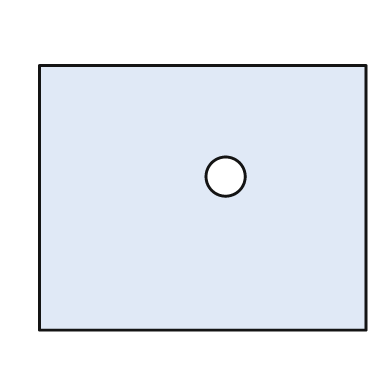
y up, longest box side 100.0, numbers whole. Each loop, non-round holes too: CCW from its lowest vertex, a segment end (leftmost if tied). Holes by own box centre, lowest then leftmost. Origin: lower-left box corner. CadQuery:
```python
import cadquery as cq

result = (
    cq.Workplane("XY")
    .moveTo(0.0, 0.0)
    .lineTo(100.0, 0.0)
    .lineTo(100.0, 81.0)
    .lineTo(0.0, 81.0)
    .close()
    .moveTo(57.0, 47.0)
    .circle(6.0)
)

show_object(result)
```